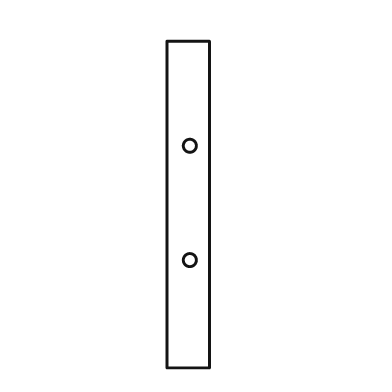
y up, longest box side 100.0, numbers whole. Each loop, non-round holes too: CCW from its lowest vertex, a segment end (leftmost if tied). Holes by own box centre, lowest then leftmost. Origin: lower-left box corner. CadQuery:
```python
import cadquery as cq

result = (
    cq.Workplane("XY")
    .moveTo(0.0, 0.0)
    .lineTo(13.0, 0.0)
    .lineTo(13.0, 100.0)
    .lineTo(0.0, 100.0)
    .close()
    .moveTo(7.0, 33.0)
    .circle(2.0)
    .moveTo(7.0, 68.0)
    .circle(2.0)
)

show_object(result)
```